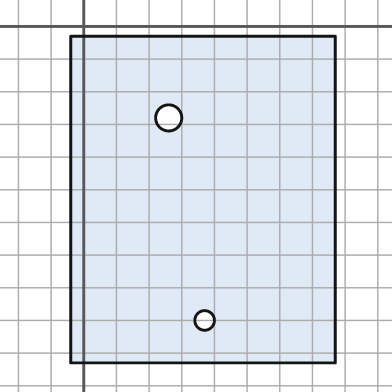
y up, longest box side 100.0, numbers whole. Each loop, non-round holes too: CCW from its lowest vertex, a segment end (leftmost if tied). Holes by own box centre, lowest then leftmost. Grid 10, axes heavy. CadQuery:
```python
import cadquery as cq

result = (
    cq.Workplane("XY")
    .moveTo(-4.0, -103.0)
    .lineTo(77.0, -103.0)
    .lineTo(77.0, -3.0)
    .lineTo(-4.0, -3.0)
    .close()
    .moveTo(37.0, -90.0)
    .circle(3.0)
    .moveTo(26.0, -28.0)
    .circle(4.0)
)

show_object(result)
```